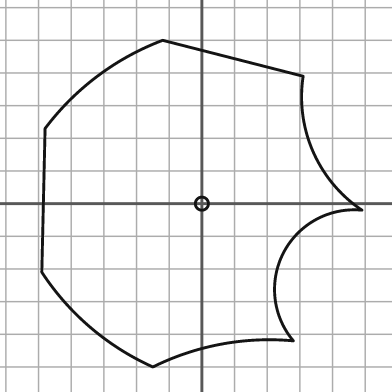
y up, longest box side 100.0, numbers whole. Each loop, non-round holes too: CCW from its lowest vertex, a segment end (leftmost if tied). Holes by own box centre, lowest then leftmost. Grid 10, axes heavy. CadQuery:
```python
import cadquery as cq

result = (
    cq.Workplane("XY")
    .moveTo(-15.0, -50.0)
    .threePointArc((6.0, -43.0), (28.0, -42.0))
    .threePointArc((25.0, -15.0), (49.0, -2.0))
    .threePointArc((34.0, 16.0), (31.0, 39.0))
    .lineTo(-12.0, 50.0)
    .threePointArc((-32.0, 39.0), (-48.0, 23.0))
    .lineTo(-49.0, -21.0)
    .threePointArc((-34.0, -38.0), (-15.0, -50.0))
    .close()
    .moveTo(0.0, 0.0)
    .circle(2.0)
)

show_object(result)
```